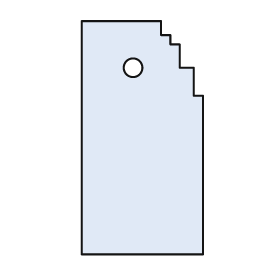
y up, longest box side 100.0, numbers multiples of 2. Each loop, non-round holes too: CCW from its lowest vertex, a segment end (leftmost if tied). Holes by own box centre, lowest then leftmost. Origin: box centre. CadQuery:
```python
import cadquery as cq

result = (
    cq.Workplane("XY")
    .moveTo(-26.0, -50.0)
    .lineTo(26.0, -50.0)
    .lineTo(26.0, 18.0)
    .lineTo(22.0, 18.0)
    .lineTo(22.0, 30.0)
    .lineTo(16.0, 30.0)
    .lineTo(16.0, 40.0)
    .lineTo(12.0, 40.0)
    .lineTo(12.0, 44.0)
    .lineTo(8.0, 44.0)
    .lineTo(8.0, 50.0)
    .lineTo(-26.0, 50.0)
    .close()
    .moveTo(-4.0, 30.0)
    .circle(4.0)
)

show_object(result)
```